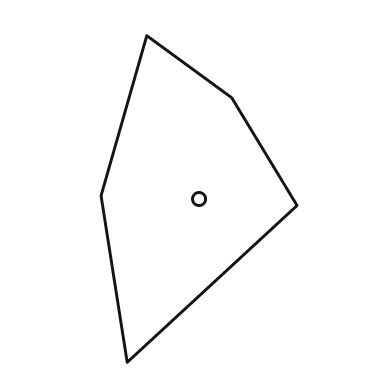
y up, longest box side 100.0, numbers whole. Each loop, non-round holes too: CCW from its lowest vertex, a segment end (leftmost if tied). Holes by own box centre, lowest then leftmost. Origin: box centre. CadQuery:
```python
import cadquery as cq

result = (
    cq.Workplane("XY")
    .moveTo(-22.0, -50.0)
    .lineTo(30.0, -2.0)
    .lineTo(10.0, 31.0)
    .lineTo(-16.0, 50.0)
    .lineTo(-30.0, 1.0)
    .close()
    .moveTo(0.0, 0.0)
    .circle(2.0)
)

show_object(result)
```